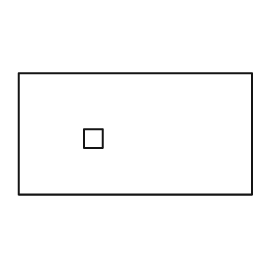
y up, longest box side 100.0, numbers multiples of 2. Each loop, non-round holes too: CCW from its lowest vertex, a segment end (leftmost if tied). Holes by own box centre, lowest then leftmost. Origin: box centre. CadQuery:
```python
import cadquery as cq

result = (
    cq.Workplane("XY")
    .moveTo(-50.0, -26.0)
    .lineTo(50.0, -26.0)
    .lineTo(50.0, 26.0)
    .lineTo(-50.0, 26.0)
    .close()
    .moveTo(-22.0, -6.0)
    .lineTo(-14.0, -6.0)
    .lineTo(-14.0, 2.0)
    .lineTo(-22.0, 2.0)
    .close()
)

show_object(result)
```